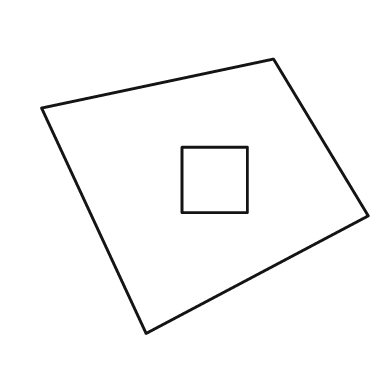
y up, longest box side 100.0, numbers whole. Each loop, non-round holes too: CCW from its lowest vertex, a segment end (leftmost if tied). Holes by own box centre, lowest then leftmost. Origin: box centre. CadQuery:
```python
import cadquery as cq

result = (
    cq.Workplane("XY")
    .moveTo(-18.0, -42.0)
    .lineTo(50.0, -6.0)
    .lineTo(21.0, 42.0)
    .lineTo(-50.0, 27.0)
    .close()
    .moveTo(-7.0, -5.0)
    .lineTo(13.0, -5.0)
    .lineTo(13.0, 15.0)
    .lineTo(-7.0, 15.0)
    .close()
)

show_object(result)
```